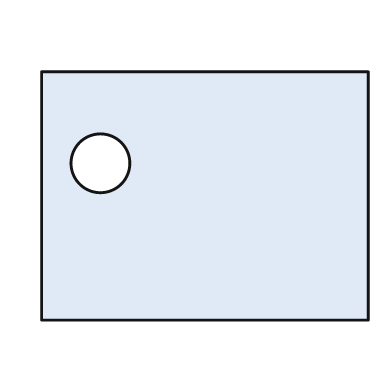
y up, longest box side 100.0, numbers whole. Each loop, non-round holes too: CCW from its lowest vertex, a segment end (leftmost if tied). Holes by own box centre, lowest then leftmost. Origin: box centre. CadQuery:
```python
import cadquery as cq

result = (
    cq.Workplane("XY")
    .moveTo(-50.0, -38.0)
    .lineTo(50.0, -38.0)
    .lineTo(50.0, 38.0)
    .lineTo(-50.0, 38.0)
    .close()
    .moveTo(-32.0, 10.0)
    .circle(9.0)
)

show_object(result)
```